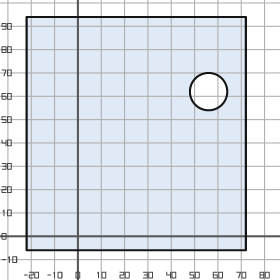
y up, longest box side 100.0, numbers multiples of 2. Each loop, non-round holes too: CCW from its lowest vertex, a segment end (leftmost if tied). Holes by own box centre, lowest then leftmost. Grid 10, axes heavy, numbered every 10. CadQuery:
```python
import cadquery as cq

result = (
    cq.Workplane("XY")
    .moveTo(-22.0, -6.0)
    .lineTo(72.0, -6.0)
    .lineTo(72.0, 94.0)
    .lineTo(-22.0, 94.0)
    .close()
    .moveTo(56.0, 62.0)
    .circle(8.0)
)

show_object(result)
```